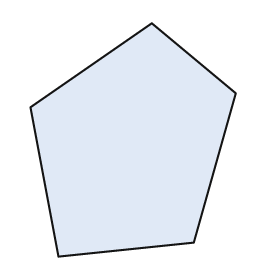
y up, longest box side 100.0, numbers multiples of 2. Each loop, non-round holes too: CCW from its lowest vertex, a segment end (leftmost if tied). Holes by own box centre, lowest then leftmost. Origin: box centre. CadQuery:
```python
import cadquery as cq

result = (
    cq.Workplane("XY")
    .moveTo(-32.0, -50.0)
    .lineTo(26.0, -44.0)
    .lineTo(44.0, 20.0)
    .lineTo(8.0, 50.0)
    .lineTo(-44.0, 14.0)
    .close()
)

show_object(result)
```